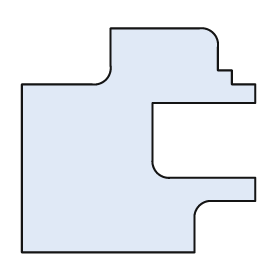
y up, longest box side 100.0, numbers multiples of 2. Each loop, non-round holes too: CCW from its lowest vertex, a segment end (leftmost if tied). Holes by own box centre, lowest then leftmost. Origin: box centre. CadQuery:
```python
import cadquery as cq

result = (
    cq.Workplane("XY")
    .moveTo(-50.0, -48.0)
    .lineTo(24.0, -48.0)
    .lineTo(24.0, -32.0)
    .threePointArc((26.0, -28.0), (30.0, -26.0))
    .lineTo(50.0, -26.0)
    .lineTo(50.0, -16.0)
    .lineTo(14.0, -16.0)
    .threePointArc((8.0, -14.0), (6.0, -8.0))
    .lineTo(6.0, 16.0)
    .lineTo(50.0, 16.0)
    .lineTo(50.0, 24.0)
    .lineTo(40.0, 24.0)
    .lineTo(40.0, 30.0)
    .lineTo(34.0, 30.0)
    .lineTo(34.0, 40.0)
    .threePointArc((32.0, 46.0), (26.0, 48.0))
    .lineTo(-12.0, 48.0)
    .lineTo(-12.0, 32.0)
    .threePointArc((-14.0, 26.0), (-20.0, 24.0))
    .lineTo(-50.0, 24.0)
    .close()
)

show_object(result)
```